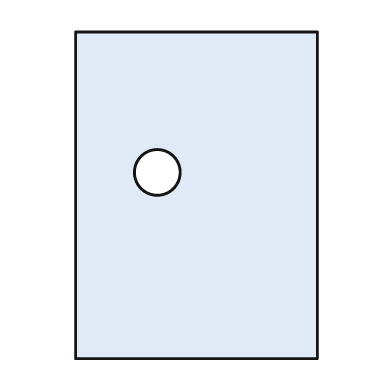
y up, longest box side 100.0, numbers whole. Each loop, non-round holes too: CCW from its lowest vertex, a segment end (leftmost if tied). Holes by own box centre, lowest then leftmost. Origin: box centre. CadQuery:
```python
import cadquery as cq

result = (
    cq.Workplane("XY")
    .moveTo(-37.0, -50.0)
    .lineTo(37.0, -50.0)
    .lineTo(37.0, 50.0)
    .lineTo(-37.0, 50.0)
    .close()
    .moveTo(-12.0, 7.0)
    .circle(7.0)
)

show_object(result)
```